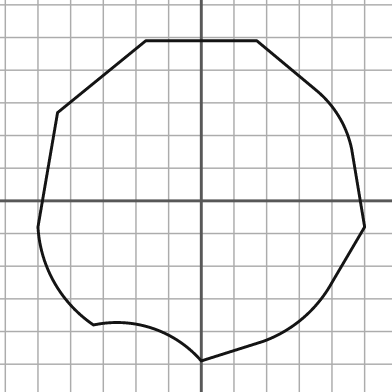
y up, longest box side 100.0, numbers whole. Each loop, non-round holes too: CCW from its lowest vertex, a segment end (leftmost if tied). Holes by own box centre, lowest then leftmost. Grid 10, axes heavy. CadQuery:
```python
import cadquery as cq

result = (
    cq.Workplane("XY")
    .moveTo(0.0, -49.0)
    .lineTo(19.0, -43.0)
    .threePointArc((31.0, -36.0), (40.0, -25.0))
    .lineTo(50.0, -8.0)
    .lineTo(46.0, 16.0)
    .threePointArc((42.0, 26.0), (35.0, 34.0))
    .lineTo(17.0, 49.0)
    .lineTo(-17.0, 49.0)
    .lineTo(-44.0, 27.0)
    .lineTo(-50.0, -8.0)
    .threePointArc((-45.0, -25.0), (-33.0, -38.0))
    .threePointArc((-15.0, -39.0), (0.0, -49.0))
    .close()
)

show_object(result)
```